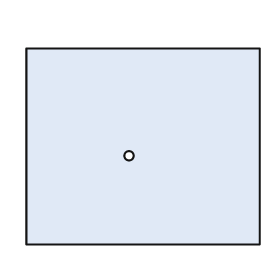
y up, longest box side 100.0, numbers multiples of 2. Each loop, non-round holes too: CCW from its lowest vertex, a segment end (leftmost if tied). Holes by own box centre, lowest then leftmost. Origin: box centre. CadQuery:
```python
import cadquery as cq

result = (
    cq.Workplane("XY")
    .moveTo(-50.0, -42.0)
    .lineTo(50.0, -42.0)
    .lineTo(50.0, 42.0)
    .lineTo(-50.0, 42.0)
    .close()
    .moveTo(-6.0, -4.0)
    .circle(2.0)
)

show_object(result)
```